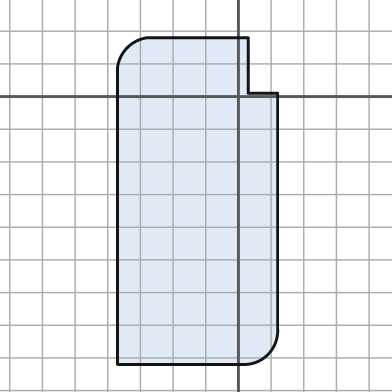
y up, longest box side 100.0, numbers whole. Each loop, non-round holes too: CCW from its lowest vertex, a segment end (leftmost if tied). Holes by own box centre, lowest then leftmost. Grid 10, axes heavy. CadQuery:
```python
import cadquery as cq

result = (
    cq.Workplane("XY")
    .moveTo(-37.0, -82.0)
    .lineTo(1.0, -82.0)
    .threePointArc((9.0, -79.0), (12.0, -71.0))
    .lineTo(12.0, 1.0)
    .lineTo(3.0, 1.0)
    .lineTo(3.0, 18.0)
    .lineTo(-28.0, 18.0)
    .threePointArc((-34.0, 15.0), (-37.0, 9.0))
    .close()
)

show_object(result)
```